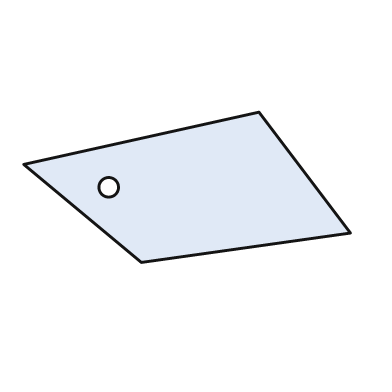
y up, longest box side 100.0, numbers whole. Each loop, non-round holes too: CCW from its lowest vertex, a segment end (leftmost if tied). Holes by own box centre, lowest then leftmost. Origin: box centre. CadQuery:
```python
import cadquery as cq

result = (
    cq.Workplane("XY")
    .moveTo(-14.0, -23.0)
    .lineTo(50.0, -14.0)
    .lineTo(22.0, 23.0)
    .lineTo(-50.0, 7.0)
    .close()
    .moveTo(-24.0, 0.0)
    .circle(3.0)
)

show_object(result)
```